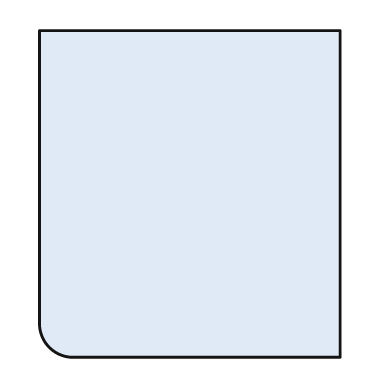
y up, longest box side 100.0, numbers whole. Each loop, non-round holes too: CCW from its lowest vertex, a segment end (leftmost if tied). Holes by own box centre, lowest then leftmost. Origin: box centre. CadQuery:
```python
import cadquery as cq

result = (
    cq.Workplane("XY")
    .moveTo(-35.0, -50.0)
    .lineTo(46.0, -50.0)
    .lineTo(46.0, 50.0)
    .lineTo(-46.0, 50.0)
    .lineTo(-46.0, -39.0)
    .threePointArc((-43.0, -47.0), (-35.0, -50.0))
    .close()
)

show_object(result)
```